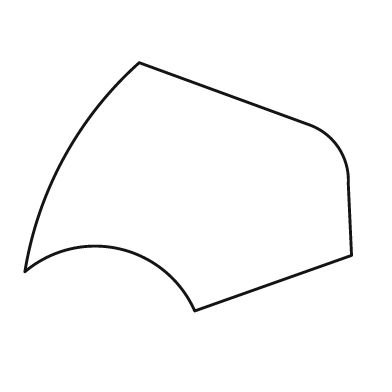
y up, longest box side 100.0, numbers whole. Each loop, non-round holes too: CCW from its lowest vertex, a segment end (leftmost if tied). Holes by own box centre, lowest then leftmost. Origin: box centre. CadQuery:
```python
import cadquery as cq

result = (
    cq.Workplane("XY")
    .moveTo(2.0, -38.0)
    .lineTo(50.0, -21.0)
    .lineTo(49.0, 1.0)
    .threePointArc((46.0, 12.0), (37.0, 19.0))
    .lineTo(-15.0, 38.0)
    .threePointArc((-38.0, 9.0), (-50.0, -26.0))
    .threePointArc((-21.0, -19.0), (2.0, -38.0))
    .close()
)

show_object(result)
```